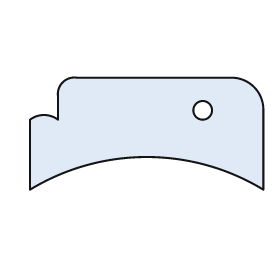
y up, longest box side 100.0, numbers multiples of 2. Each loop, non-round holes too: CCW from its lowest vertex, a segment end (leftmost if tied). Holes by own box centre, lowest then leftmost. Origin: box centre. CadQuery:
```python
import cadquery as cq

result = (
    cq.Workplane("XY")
    .moveTo(-50.0, -24.0)
    .threePointArc((0.0, -10.0), (50.0, -24.0))
    .lineTo(50.0, 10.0)
    .threePointArc((46.0, 20.0), (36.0, 24.0))
    .lineTo(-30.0, 24.0)
    .threePointArc((-36.0, 22.0), (-38.0, 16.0))
    .lineTo(-38.0, 6.0)
    .threePointArc((-44.0, 8.0), (-50.0, 6.0))
    .close()
    .moveTo(24.0, 10.0)
    .circle(4.0)
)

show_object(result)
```